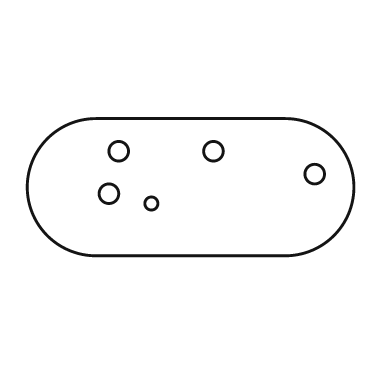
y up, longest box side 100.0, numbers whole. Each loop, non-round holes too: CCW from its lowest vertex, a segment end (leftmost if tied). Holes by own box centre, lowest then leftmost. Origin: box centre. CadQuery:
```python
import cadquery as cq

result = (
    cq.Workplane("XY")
    .moveTo(-29.0, -21.0)
    .lineTo(29.0, -21.0)
    .threePointArc((50.0, 0.0), (29.0, 21.0))
    .lineTo(-29.0, 21.0)
    .threePointArc((-50.0, 0.0), (-29.0, -21.0))
    .close()
    .moveTo(-12.0, -5.0)
    .circle(2.0)
    .moveTo(-25.0, -2.0)
    .circle(3.0)
    .moveTo(38.0, 4.0)
    .circle(3.0)
    .moveTo(-22.0, 11.0)
    .circle(3.0)
    .moveTo(7.0, 11.0)
    .circle(3.0)
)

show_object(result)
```